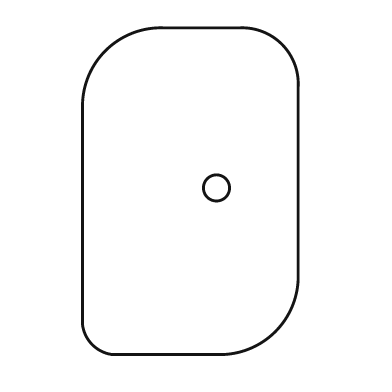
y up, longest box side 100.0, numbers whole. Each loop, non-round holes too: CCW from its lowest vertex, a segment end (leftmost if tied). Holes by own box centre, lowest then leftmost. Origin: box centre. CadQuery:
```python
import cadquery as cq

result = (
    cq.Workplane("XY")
    .moveTo(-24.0, -50.0)
    .lineTo(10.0, -50.0)
    .threePointArc((26.0, -43.0), (33.0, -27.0))
    .lineTo(33.0, 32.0)
    .threePointArc((28.0, 45.0), (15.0, 50.0))
    .lineTo(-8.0, 50.0)
    .threePointArc((-26.0, 43.0), (-33.0, 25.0))
    .lineTo(-33.0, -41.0)
    .threePointArc((-30.0, -47.0), (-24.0, -50.0))
    .close()
    .moveTo(8.0, 1.0)
    .circle(4.0)
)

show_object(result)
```